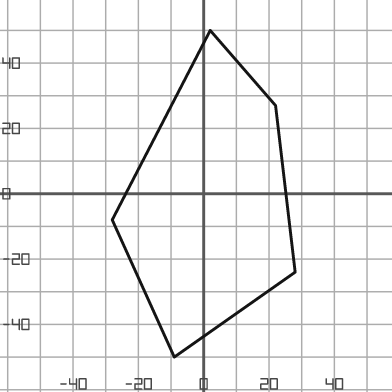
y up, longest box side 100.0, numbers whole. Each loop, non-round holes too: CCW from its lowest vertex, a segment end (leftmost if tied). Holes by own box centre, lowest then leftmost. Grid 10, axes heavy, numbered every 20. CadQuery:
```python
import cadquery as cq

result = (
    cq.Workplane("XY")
    .moveTo(-9.0, -50.0)
    .lineTo(28.0, -24.0)
    .lineTo(22.0, 27.0)
    .lineTo(2.0, 50.0)
    .lineTo(-28.0, -8.0)
    .close()
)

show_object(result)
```